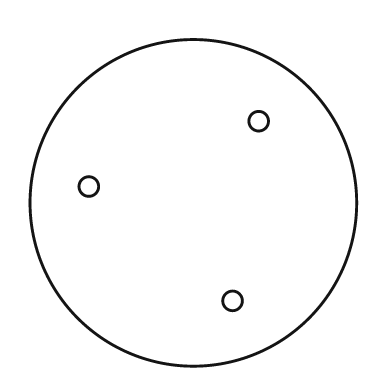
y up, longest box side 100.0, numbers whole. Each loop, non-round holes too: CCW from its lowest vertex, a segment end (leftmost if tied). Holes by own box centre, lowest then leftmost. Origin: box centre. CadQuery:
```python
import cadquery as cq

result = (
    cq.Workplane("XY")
    .moveTo(0.0, 0.0)
    .circle(50.0)
    .moveTo(12.0, -30.0)
    .circle(3.0)
    .moveTo(-32.0, 5.0)
    .circle(3.0)
    .moveTo(20.0, 25.0)
    .circle(3.0)
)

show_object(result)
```